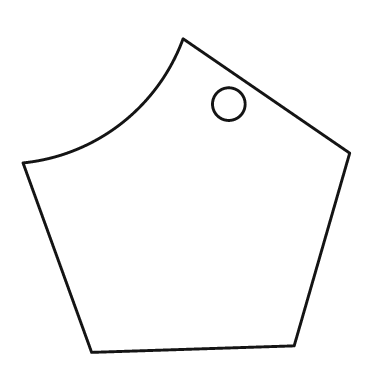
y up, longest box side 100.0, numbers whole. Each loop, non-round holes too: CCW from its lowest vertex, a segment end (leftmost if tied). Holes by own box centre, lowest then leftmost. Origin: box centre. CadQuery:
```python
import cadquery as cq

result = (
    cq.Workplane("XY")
    .moveTo(-29.0, -48.0)
    .lineTo(33.0, -46.0)
    .lineTo(50.0, 13.0)
    .lineTo(-1.0, 48.0)
    .threePointArc((-20.0, 22.0), (-50.0, 10.0))
    .close()
    .moveTo(13.0, 28.0)
    .circle(5.0)
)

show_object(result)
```